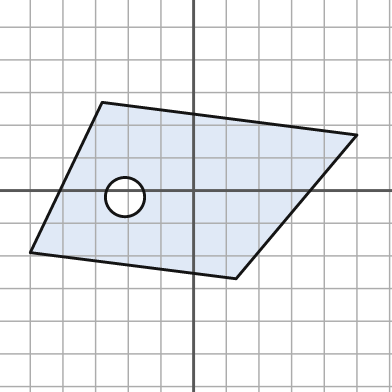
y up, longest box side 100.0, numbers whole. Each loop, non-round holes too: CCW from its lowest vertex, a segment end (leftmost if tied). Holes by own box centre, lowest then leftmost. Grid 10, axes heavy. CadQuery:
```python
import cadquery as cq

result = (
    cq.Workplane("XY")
    .moveTo(13.0, -27.0)
    .lineTo(50.0, 17.0)
    .lineTo(-28.0, 27.0)
    .lineTo(-50.0, -19.0)
    .close()
    .moveTo(-21.0, -2.0)
    .circle(6.0)
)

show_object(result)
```